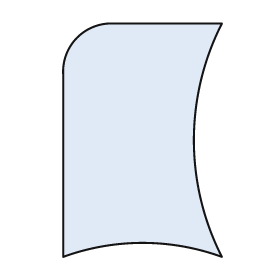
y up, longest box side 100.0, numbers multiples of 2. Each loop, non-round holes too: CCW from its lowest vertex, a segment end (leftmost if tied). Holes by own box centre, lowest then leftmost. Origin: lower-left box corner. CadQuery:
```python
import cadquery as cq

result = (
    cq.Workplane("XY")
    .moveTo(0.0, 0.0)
    .threePointArc((34.0, 6.0), (68.0, 0.0))
    .threePointArc((56.0, 50.0), (68.0, 100.0))
    .lineTo(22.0, 100.0)
    .threePointArc((6.0, 94.0), (0.0, 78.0))
    .close()
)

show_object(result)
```